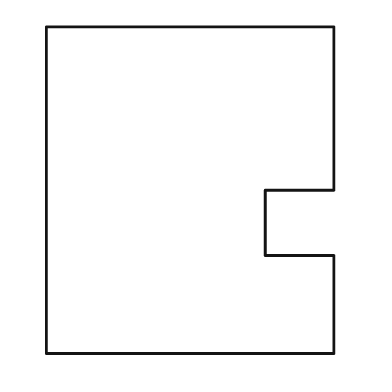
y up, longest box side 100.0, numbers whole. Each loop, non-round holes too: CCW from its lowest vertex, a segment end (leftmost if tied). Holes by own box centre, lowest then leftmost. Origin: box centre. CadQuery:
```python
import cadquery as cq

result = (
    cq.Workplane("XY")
    .moveTo(-44.0, -50.0)
    .lineTo(44.0, -50.0)
    .lineTo(44.0, -20.0)
    .lineTo(23.0, -20.0)
    .lineTo(23.0, 0.0)
    .lineTo(44.0, 0.0)
    .lineTo(44.0, 50.0)
    .lineTo(-44.0, 50.0)
    .close()
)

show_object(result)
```